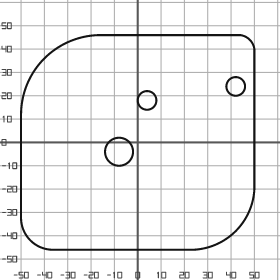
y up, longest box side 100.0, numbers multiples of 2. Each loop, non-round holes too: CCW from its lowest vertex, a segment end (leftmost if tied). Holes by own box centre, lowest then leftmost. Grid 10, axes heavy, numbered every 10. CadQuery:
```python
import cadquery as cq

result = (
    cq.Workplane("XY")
    .moveTo(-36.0, -46.0)
    .lineTo(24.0, -46.0)
    .threePointArc((42.0, -38.0), (50.0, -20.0))
    .lineTo(50.0, 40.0)
    .threePointArc((48.0, 44.0), (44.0, 46.0))
    .lineTo(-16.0, 46.0)
    .threePointArc((-40.0, 36.0), (-50.0, 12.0))
    .lineTo(-50.0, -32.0)
    .threePointArc((-46.0, -42.0), (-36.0, -46.0))
    .close()
    .moveTo(-8.0, -4.0)
    .circle(6.0)
    .moveTo(4.0, 18.0)
    .circle(4.0)
    .moveTo(42.0, 24.0)
    .circle(4.0)
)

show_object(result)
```